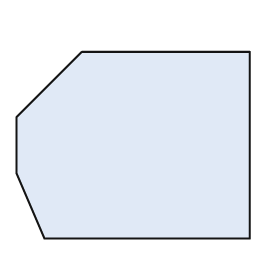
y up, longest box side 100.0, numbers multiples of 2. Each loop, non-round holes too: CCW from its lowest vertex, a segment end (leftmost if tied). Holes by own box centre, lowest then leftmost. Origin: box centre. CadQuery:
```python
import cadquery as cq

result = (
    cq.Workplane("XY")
    .moveTo(-38.0, -40.0)
    .lineTo(50.0, -40.0)
    .lineTo(50.0, 40.0)
    .lineTo(-22.0, 40.0)
    .lineTo(-50.0, 12.0)
    .lineTo(-50.0, -12.0)
    .close()
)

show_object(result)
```